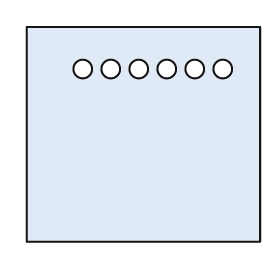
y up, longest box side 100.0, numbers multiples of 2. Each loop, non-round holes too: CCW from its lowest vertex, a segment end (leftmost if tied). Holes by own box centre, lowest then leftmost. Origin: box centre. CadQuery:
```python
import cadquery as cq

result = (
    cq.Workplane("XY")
    .moveTo(-50.0, -46.0)
    .lineTo(50.0, -46.0)
    .lineTo(50.0, 46.0)
    .lineTo(-50.0, 46.0)
    .close()
    .moveTo(-26.0, 28.0)
    .circle(4.0)
    .moveTo(-14.0, 28.0)
    .circle(4.0)
    .moveTo(-2.0, 28.0)
    .circle(4.0)
    .moveTo(10.0, 28.0)
    .circle(4.0)
    .moveTo(22.0, 28.0)
    .circle(4.0)
    .moveTo(34.0, 28.0)
    .circle(4.0)
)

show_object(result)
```